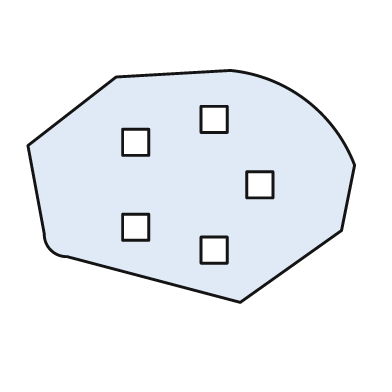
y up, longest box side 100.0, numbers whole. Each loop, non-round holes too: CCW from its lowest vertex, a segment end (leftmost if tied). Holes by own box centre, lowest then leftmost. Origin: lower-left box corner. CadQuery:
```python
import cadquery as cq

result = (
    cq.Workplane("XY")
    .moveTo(65.0, 0.0)
    .lineTo(96.0, 22.0)
    .lineTo(100.0, 42.0)
    .threePointArc((85.0, 62.0), (62.0, 71.0))
    .lineTo(27.0, 69.0)
    .lineTo(0.0, 48.0)
    .lineTo(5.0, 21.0)
    .threePointArc((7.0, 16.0), (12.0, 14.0))
    .close()
    .moveTo(53.0, 12.0)
    .lineTo(61.0, 12.0)
    .lineTo(61.0, 20.0)
    .lineTo(53.0, 20.0)
    .close()
    .moveTo(29.0, 19.0)
    .lineTo(37.0, 19.0)
    .lineTo(37.0, 27.0)
    .lineTo(29.0, 27.0)
    .close()
    .moveTo(67.0, 32.0)
    .lineTo(75.0, 32.0)
    .lineTo(75.0, 40.0)
    .lineTo(67.0, 40.0)
    .close()
    .moveTo(29.0, 45.0)
    .lineTo(37.0, 45.0)
    .lineTo(37.0, 53.0)
    .lineTo(29.0, 53.0)
    .close()
    .moveTo(53.0, 52.0)
    .lineTo(61.0, 52.0)
    .lineTo(61.0, 60.0)
    .lineTo(53.0, 60.0)
    .close()
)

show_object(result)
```